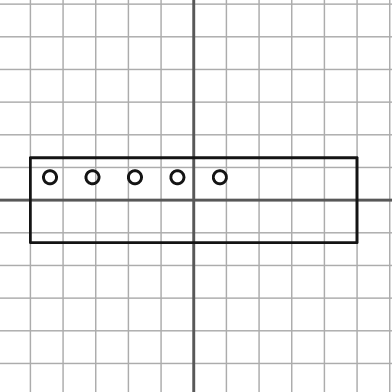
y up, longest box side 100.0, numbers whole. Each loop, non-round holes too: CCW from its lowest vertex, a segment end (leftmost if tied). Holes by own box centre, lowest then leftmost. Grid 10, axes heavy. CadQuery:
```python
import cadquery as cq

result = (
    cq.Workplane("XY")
    .moveTo(-50.0, -13.0)
    .lineTo(50.0, -13.0)
    .lineTo(50.0, 13.0)
    .lineTo(-50.0, 13.0)
    .close()
    .moveTo(-44.0, 7.0)
    .circle(2.0)
    .moveTo(-31.0, 7.0)
    .circle(2.0)
    .moveTo(-18.0, 7.0)
    .circle(2.0)
    .moveTo(-5.0, 7.0)
    .circle(2.0)
    .moveTo(8.0, 7.0)
    .circle(2.0)
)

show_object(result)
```